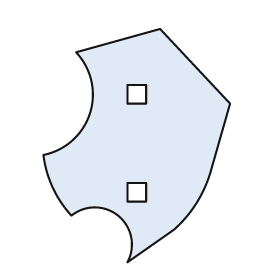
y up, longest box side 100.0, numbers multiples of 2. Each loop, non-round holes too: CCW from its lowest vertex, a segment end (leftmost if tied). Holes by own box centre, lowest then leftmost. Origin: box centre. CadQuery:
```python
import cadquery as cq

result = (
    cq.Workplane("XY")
    .moveTo(-4.0, -50.0)
    .lineTo(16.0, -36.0)
    .threePointArc((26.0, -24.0), (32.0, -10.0))
    .lineTo(40.0, 18.0)
    .lineTo(10.0, 50.0)
    .lineTo(-26.0, 40.0)
    .threePointArc((-20.0, 14.0), (-40.0, -4.0))
    .threePointArc((-36.0, -18.0), (-28.0, -30.0))
    .threePointArc((-8.0, -30.0), (-4.0, -50.0))
    .close()
    .moveTo(-4.0, -24.0)
    .lineTo(4.0, -24.0)
    .lineTo(4.0, -16.0)
    .lineTo(-4.0, -16.0)
    .close()
    .moveTo(-4.0, 18.0)
    .lineTo(4.0, 18.0)
    .lineTo(4.0, 26.0)
    .lineTo(-4.0, 26.0)
    .close()
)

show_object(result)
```